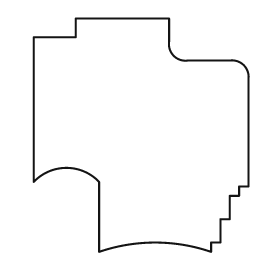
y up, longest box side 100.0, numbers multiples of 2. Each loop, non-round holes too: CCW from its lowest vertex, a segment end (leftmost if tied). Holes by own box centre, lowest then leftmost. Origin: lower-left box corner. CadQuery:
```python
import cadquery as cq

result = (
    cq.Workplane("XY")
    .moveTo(28.0, 0.0)
    .threePointArc((52.0, 4.0), (76.0, 0.0))
    .lineTo(76.0, 4.0)
    .lineTo(80.0, 4.0)
    .lineTo(80.0, 14.0)
    .lineTo(84.0, 14.0)
    .lineTo(84.0, 24.0)
    .lineTo(88.0, 24.0)
    .lineTo(88.0, 28.0)
    .lineTo(92.0, 28.0)
    .lineTo(92.0, 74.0)
    .threePointArc((90.0, 80.0), (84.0, 82.0))
    .lineTo(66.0, 82.0)
    .threePointArc((60.0, 84.0), (58.0, 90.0))
    .lineTo(58.0, 100.0)
    .lineTo(18.0, 100.0)
    .lineTo(18.0, 92.0)
    .lineTo(0.0, 92.0)
    .lineTo(0.0, 30.0)
    .threePointArc((14.0, 36.0), (28.0, 30.0))
    .close()
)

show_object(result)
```